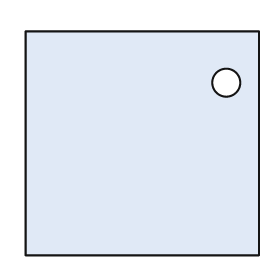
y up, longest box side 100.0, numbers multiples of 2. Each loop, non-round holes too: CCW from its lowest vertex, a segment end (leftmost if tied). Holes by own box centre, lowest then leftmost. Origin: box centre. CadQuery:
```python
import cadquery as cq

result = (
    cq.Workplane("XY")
    .moveTo(-50.0, -48.0)
    .lineTo(50.0, -48.0)
    .lineTo(50.0, 48.0)
    .lineTo(-50.0, 48.0)
    .close()
    .moveTo(36.0, 26.0)
    .circle(6.0)
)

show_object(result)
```